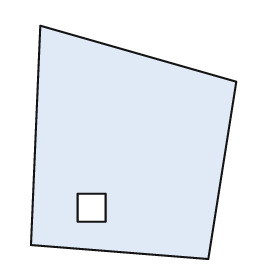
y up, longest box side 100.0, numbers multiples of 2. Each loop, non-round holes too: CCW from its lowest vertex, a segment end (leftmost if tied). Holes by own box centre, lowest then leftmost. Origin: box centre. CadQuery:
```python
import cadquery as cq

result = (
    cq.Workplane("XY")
    .moveTo(32.0, -50.0)
    .lineTo(44.0, 26.0)
    .lineTo(-40.0, 50.0)
    .lineTo(-44.0, -44.0)
    .close()
    .moveTo(-24.0, -34.0)
    .lineTo(-12.0, -34.0)
    .lineTo(-12.0, -22.0)
    .lineTo(-24.0, -22.0)
    .close()
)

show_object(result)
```